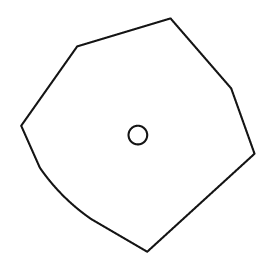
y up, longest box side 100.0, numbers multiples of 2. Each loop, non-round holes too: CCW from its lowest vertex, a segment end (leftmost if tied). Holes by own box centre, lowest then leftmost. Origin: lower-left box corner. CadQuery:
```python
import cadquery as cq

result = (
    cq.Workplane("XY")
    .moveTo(54.0, 0.0)
    .lineTo(100.0, 42.0)
    .lineTo(90.0, 70.0)
    .lineTo(64.0, 100.0)
    .lineTo(24.0, 88.0)
    .lineTo(0.0, 54.0)
    .lineTo(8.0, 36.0)
    .threePointArc((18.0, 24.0), (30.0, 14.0))
    .close()
    .moveTo(50.0, 50.0)
    .circle(4.0)
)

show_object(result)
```